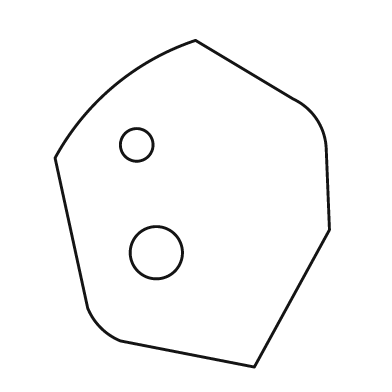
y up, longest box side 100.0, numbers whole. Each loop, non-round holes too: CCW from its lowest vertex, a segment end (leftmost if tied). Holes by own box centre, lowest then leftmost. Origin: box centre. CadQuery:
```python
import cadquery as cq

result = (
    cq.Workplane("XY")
    .moveTo(19.0, -50.0)
    .lineTo(42.0, -8.0)
    .lineTo(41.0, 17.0)
    .threePointArc((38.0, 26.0), (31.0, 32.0))
    .lineTo(1.0, 50.0)
    .threePointArc((-24.0, 36.0), (-42.0, 14.0))
    .lineTo(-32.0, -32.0)
    .threePointArc((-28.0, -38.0), (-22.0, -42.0))
    .close()
    .moveTo(-11.0, -15.0)
    .circle(8.0)
    .moveTo(-17.0, 18.0)
    .circle(5.0)
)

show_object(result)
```